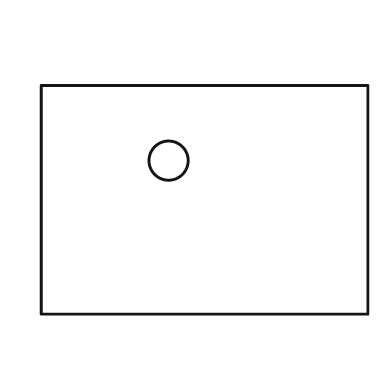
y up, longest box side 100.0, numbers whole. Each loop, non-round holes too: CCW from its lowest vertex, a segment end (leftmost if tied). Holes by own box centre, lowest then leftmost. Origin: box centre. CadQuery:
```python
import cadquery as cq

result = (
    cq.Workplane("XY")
    .moveTo(-50.0, -35.0)
    .lineTo(50.0, -35.0)
    .lineTo(50.0, 35.0)
    .lineTo(-50.0, 35.0)
    .close()
    .moveTo(-11.0, 12.0)
    .circle(6.0)
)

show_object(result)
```